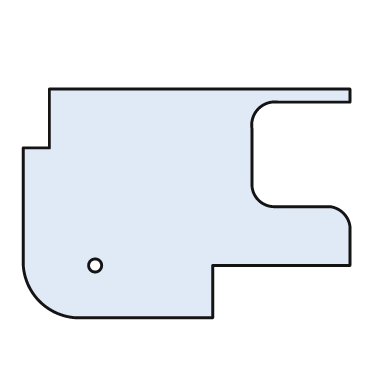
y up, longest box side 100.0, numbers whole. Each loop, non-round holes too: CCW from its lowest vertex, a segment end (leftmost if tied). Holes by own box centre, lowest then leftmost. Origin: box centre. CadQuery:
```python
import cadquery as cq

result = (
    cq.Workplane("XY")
    .moveTo(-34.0, -35.0)
    .lineTo(8.0, -35.0)
    .lineTo(8.0, -19.0)
    .lineTo(50.0, -19.0)
    .lineTo(50.0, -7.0)
    .threePointArc((48.0, -3.0), (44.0, -1.0))
    .lineTo(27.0, -1.0)
    .threePointArc((22.0, 1.0), (20.0, 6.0))
    .lineTo(20.0, 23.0)
    .threePointArc((22.0, 29.0), (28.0, 31.0))
    .lineTo(50.0, 31.0)
    .lineTo(50.0, 35.0)
    .lineTo(-42.0, 35.0)
    .lineTo(-42.0, 17.0)
    .lineTo(-50.0, 17.0)
    .lineTo(-50.0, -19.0)
    .threePointArc((-45.0, -30.0), (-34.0, -35.0))
    .close()
    .moveTo(-28.0, -19.0)
    .circle(2.0)
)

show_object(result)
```